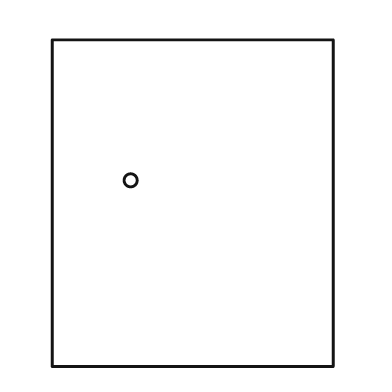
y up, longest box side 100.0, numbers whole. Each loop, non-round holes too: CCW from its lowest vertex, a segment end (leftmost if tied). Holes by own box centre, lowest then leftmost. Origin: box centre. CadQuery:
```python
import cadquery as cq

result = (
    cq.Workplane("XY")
    .moveTo(-43.0, -50.0)
    .lineTo(43.0, -50.0)
    .lineTo(43.0, 50.0)
    .lineTo(-43.0, 50.0)
    .close()
    .moveTo(-19.0, 7.0)
    .circle(2.0)
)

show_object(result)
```